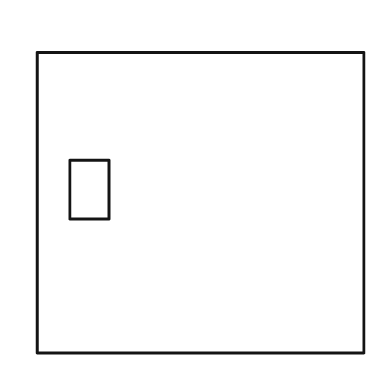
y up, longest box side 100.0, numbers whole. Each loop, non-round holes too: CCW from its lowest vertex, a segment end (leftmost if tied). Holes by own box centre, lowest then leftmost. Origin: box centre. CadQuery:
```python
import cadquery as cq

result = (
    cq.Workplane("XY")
    .moveTo(-50.0, -46.0)
    .lineTo(50.0, -46.0)
    .lineTo(50.0, 46.0)
    .lineTo(-50.0, 46.0)
    .close()
    .moveTo(-40.0, -5.0)
    .lineTo(-28.0, -5.0)
    .lineTo(-28.0, 13.0)
    .lineTo(-40.0, 13.0)
    .close()
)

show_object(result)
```